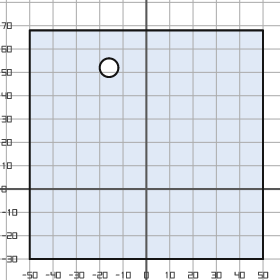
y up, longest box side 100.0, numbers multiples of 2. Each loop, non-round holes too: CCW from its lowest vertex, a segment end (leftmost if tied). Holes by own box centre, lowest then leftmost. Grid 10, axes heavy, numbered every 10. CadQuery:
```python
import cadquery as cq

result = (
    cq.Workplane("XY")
    .moveTo(-50.0, -30.0)
    .lineTo(50.0, -30.0)
    .lineTo(50.0, 68.0)
    .lineTo(-50.0, 68.0)
    .close()
    .moveTo(-16.0, 52.0)
    .circle(4.0)
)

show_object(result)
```